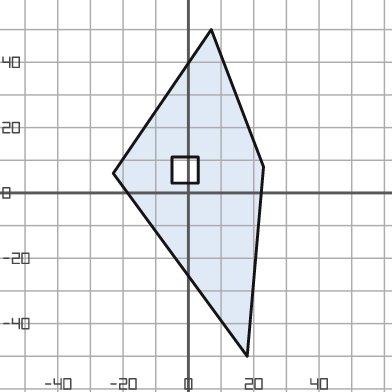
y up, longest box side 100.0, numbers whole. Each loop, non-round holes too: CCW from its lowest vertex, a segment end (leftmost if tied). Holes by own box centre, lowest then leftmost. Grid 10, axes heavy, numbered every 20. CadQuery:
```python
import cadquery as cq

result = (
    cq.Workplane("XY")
    .moveTo(18.0, -50.0)
    .lineTo(23.0, 8.0)
    .lineTo(7.0, 50.0)
    .lineTo(-23.0, 6.0)
    .close()
    .moveTo(-5.0, 3.0)
    .lineTo(3.0, 3.0)
    .lineTo(3.0, 11.0)
    .lineTo(-5.0, 11.0)
    .close()
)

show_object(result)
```